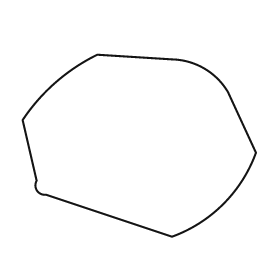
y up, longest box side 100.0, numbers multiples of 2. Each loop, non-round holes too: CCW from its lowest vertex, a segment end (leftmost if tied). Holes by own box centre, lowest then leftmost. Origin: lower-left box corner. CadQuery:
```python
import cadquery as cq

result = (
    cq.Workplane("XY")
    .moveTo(64.0, 0.0)
    .threePointArc((86.0, 14.0), (100.0, 36.0))
    .lineTo(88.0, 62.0)
    .threePointArc((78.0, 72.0), (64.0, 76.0))
    .lineTo(32.0, 78.0)
    .threePointArc((14.0, 66.0), (0.0, 50.0))
    .lineTo(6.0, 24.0)
    .threePointArc((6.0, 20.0), (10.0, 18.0))
    .close()
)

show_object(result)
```